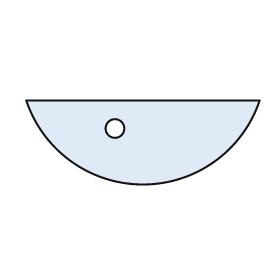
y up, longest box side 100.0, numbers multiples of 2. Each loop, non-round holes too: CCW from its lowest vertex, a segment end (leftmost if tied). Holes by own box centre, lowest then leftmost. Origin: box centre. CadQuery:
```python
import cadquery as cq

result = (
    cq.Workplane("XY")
    .moveTo(-50.0, 18.0)
    .threePointArc((0.0, -18.0), (50.0, 18.0))
    .close()
    .moveTo(-12.0, 6.0)
    .circle(4.0)
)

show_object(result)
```